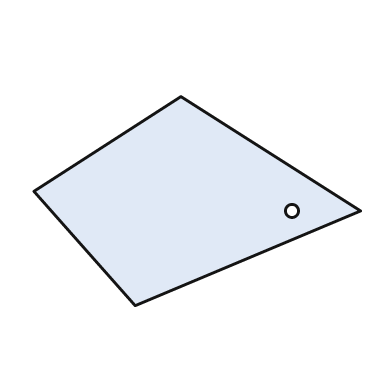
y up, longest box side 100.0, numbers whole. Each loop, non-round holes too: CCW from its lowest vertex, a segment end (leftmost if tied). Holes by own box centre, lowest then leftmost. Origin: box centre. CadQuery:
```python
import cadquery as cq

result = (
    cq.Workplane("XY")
    .moveTo(-19.0, -32.0)
    .lineTo(50.0, -3.0)
    .lineTo(-5.0, 32.0)
    .lineTo(-50.0, 3.0)
    .close()
    .moveTo(29.0, -3.0)
    .circle(2.0)
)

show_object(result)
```